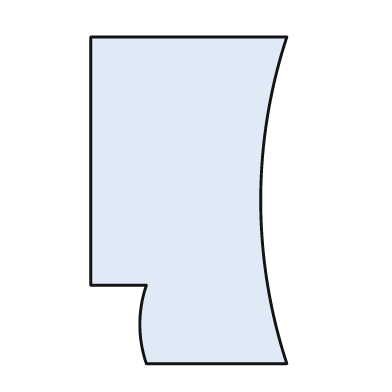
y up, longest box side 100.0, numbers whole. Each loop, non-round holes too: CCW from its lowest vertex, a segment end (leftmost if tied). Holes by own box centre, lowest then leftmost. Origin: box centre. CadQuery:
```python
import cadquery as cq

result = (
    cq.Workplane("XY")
    .moveTo(-13.0, -50.0)
    .lineTo(30.0, -50.0)
    .threePointArc((22.0, 0.0), (30.0, 50.0))
    .lineTo(-30.0, 50.0)
    .lineTo(-30.0, -26.0)
    .lineTo(-13.0, -26.0)
    .threePointArc((-15.0, -38.0), (-13.0, -50.0))
    .close()
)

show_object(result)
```